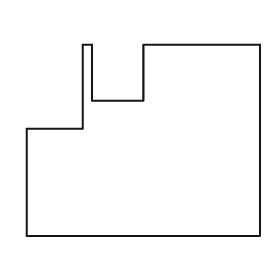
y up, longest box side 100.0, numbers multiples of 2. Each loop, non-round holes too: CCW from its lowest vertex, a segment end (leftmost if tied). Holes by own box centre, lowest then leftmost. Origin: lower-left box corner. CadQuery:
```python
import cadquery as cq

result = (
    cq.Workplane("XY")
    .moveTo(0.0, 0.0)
    .lineTo(100.0, 0.0)
    .lineTo(100.0, 82.0)
    .lineTo(50.0, 82.0)
    .lineTo(50.0, 58.0)
    .lineTo(28.0, 58.0)
    .lineTo(28.0, 82.0)
    .lineTo(24.0, 82.0)
    .lineTo(24.0, 46.0)
    .lineTo(0.0, 46.0)
    .close()
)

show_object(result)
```